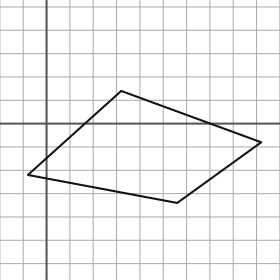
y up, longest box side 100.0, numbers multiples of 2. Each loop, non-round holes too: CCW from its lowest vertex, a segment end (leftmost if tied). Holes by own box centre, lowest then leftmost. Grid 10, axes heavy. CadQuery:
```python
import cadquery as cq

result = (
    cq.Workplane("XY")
    .moveTo(56.0, -34.0)
    .lineTo(92.0, -8.0)
    .lineTo(32.0, 14.0)
    .lineTo(-8.0, -22.0)
    .close()
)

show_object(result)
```